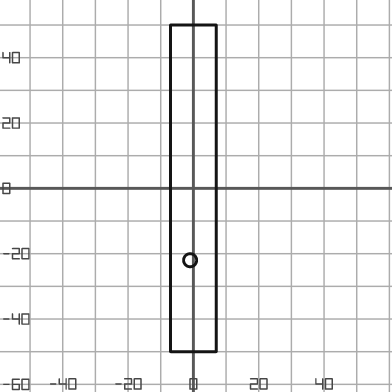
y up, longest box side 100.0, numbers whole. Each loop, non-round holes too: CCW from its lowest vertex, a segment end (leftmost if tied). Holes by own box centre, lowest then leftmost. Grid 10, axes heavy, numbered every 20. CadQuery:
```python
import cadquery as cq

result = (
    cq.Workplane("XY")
    .moveTo(-7.0, -50.0)
    .lineTo(7.0, -50.0)
    .lineTo(7.0, 50.0)
    .lineTo(-7.0, 50.0)
    .close()
    .moveTo(-1.0, -22.0)
    .circle(2.0)
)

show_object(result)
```